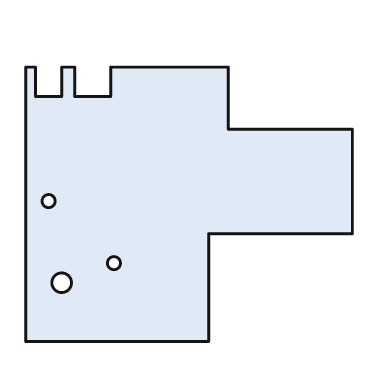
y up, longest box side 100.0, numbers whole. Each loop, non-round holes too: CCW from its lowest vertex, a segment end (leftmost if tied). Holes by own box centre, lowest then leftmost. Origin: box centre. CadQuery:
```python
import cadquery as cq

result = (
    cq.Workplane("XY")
    .moveTo(-50.0, -42.0)
    .lineTo(6.0, -42.0)
    .lineTo(6.0, -9.0)
    .lineTo(50.0, -9.0)
    .lineTo(50.0, 23.0)
    .lineTo(12.0, 23.0)
    .lineTo(12.0, 42.0)
    .lineTo(-24.0, 42.0)
    .lineTo(-24.0, 33.0)
    .lineTo(-35.0, 33.0)
    .lineTo(-35.0, 42.0)
    .lineTo(-39.0, 42.0)
    .lineTo(-39.0, 33.0)
    .lineTo(-47.0, 33.0)
    .lineTo(-47.0, 42.0)
    .lineTo(-50.0, 42.0)
    .close()
    .moveTo(-39.0, -24.0)
    .circle(3.0)
    .moveTo(-23.0, -18.0)
    .circle(2.0)
    .moveTo(-43.0, 1.0)
    .circle(2.0)
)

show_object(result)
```